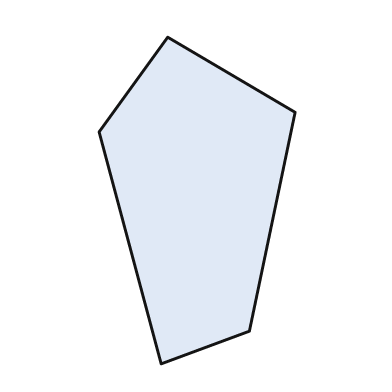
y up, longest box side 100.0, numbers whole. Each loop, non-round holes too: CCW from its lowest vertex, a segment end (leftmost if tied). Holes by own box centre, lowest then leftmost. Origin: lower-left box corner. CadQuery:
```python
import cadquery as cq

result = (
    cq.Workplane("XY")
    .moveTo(19.0, 0.0)
    .lineTo(46.0, 10.0)
    .lineTo(60.0, 77.0)
    .lineTo(21.0, 100.0)
    .lineTo(0.0, 71.0)
    .close()
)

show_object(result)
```